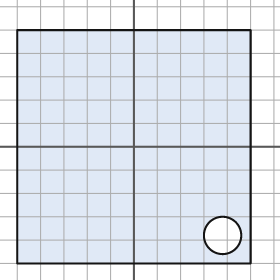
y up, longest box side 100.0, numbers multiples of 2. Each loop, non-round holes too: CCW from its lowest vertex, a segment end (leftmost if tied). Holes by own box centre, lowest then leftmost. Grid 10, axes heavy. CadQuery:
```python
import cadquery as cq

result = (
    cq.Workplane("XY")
    .moveTo(-50.0, -50.0)
    .lineTo(50.0, -50.0)
    .lineTo(50.0, 50.0)
    .lineTo(-50.0, 50.0)
    .close()
    .moveTo(38.0, -38.0)
    .circle(8.0)
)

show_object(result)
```